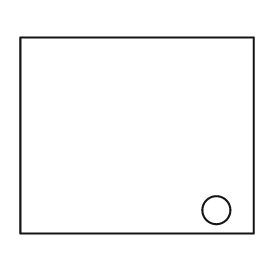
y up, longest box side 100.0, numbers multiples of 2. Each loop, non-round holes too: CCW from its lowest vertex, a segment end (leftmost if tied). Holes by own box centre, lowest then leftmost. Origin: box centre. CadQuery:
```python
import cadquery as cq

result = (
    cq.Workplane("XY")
    .moveTo(-50.0, -42.0)
    .lineTo(50.0, -42.0)
    .lineTo(50.0, 42.0)
    .lineTo(-50.0, 42.0)
    .close()
    .moveTo(34.0, -32.0)
    .circle(6.0)
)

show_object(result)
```